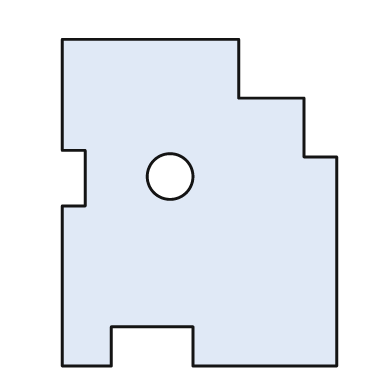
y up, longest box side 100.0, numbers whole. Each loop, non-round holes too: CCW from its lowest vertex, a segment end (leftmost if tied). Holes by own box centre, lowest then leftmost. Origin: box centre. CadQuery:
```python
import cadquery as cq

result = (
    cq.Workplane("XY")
    .moveTo(-42.0, -50.0)
    .lineTo(-27.0, -50.0)
    .lineTo(-27.0, -38.0)
    .lineTo(-2.0, -38.0)
    .lineTo(-2.0, -50.0)
    .lineTo(42.0, -50.0)
    .lineTo(42.0, 14.0)
    .lineTo(32.0, 14.0)
    .lineTo(32.0, 32.0)
    .lineTo(12.0, 32.0)
    .lineTo(12.0, 50.0)
    .lineTo(-42.0, 50.0)
    .lineTo(-42.0, 16.0)
    .lineTo(-35.0, 16.0)
    .lineTo(-35.0, -1.0)
    .lineTo(-42.0, -1.0)
    .close()
    .moveTo(-9.0, 8.0)
    .circle(7.0)
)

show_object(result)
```